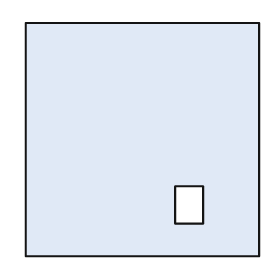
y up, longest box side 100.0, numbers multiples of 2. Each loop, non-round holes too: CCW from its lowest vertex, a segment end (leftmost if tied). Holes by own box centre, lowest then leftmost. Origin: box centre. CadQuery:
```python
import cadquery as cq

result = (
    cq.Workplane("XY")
    .moveTo(-50.0, -50.0)
    .lineTo(50.0, -50.0)
    .lineTo(50.0, 50.0)
    .lineTo(-50.0, 50.0)
    .close()
    .moveTo(14.0, -36.0)
    .lineTo(26.0, -36.0)
    .lineTo(26.0, -20.0)
    .lineTo(14.0, -20.0)
    .close()
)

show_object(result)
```